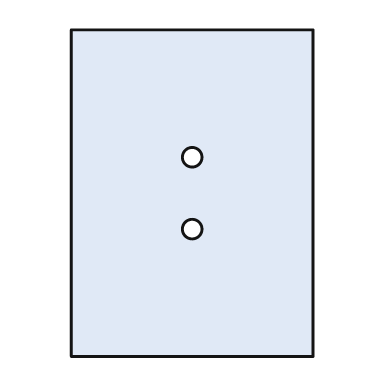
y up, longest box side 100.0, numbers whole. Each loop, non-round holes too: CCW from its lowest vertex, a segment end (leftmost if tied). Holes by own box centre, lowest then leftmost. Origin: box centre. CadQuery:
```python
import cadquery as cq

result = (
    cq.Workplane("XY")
    .moveTo(-37.0, -50.0)
    .lineTo(37.0, -50.0)
    .lineTo(37.0, 50.0)
    .lineTo(-37.0, 50.0)
    .close()
    .moveTo(0.0, -11.0)
    .circle(3.0)
    .moveTo(0.0, 11.0)
    .circle(3.0)
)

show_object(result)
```